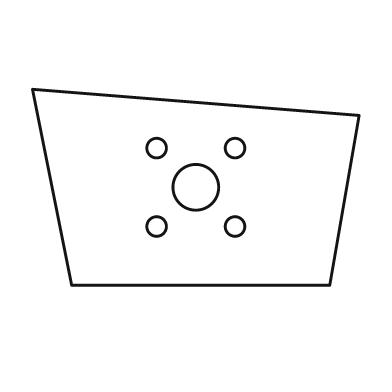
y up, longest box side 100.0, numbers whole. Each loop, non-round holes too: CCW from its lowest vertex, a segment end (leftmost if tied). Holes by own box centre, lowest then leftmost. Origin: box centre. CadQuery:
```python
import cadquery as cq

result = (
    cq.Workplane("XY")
    .moveTo(-38.0, -30.0)
    .lineTo(41.0, -30.0)
    .lineTo(50.0, 22.0)
    .lineTo(-50.0, 30.0)
    .close()
    .moveTo(-12.0, -12.0)
    .circle(3.0)
    .moveTo(12.0, -12.0)
    .circle(3.0)
    .moveTo(0.0, 0.0)
    .circle(7.0)
    .moveTo(-12.0, 12.0)
    .circle(3.0)
    .moveTo(12.0, 12.0)
    .circle(3.0)
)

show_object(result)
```